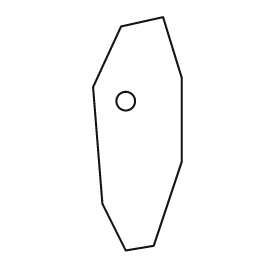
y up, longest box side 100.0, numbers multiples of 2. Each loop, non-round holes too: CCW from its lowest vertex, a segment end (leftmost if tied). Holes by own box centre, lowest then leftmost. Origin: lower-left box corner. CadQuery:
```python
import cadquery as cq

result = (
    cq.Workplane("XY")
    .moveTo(14.0, 0.0)
    .lineTo(26.0, 2.0)
    .lineTo(38.0, 38.0)
    .lineTo(38.0, 74.0)
    .lineTo(30.0, 100.0)
    .lineTo(12.0, 96.0)
    .lineTo(0.0, 70.0)
    .lineTo(4.0, 20.0)
    .close()
    .moveTo(14.0, 64.0)
    .circle(4.0)
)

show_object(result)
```